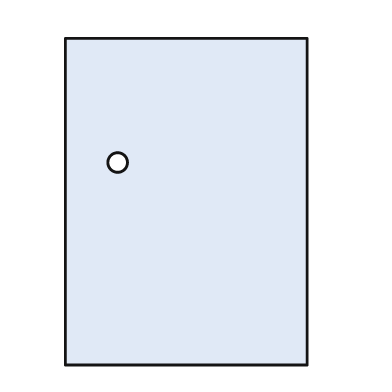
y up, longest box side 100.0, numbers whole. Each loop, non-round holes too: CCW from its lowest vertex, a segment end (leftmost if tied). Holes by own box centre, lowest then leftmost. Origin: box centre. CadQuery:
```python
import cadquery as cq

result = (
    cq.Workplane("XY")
    .moveTo(-37.0, -50.0)
    .lineTo(37.0, -50.0)
    .lineTo(37.0, 50.0)
    .lineTo(-37.0, 50.0)
    .close()
    .moveTo(-21.0, 12.0)
    .circle(3.0)
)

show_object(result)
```